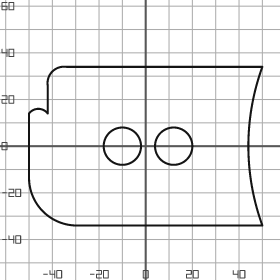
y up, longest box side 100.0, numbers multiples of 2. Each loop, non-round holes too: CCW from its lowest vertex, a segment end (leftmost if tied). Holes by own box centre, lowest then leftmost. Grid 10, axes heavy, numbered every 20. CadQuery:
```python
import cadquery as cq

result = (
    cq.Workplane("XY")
    .moveTo(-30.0, -34.0)
    .lineTo(50.0, -34.0)
    .threePointArc((44.0, 0.0), (50.0, 34.0))
    .lineTo(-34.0, 34.0)
    .threePointArc((-40.0, 32.0), (-42.0, 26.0))
    .lineTo(-42.0, 14.0)
    .threePointArc((-46.0, 16.0), (-50.0, 14.0))
    .lineTo(-50.0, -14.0)
    .threePointArc((-44.0, -28.0), (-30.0, -34.0))
    .close()
    .moveTo(-10.0, 0.0)
    .circle(8.0)
    .moveTo(12.0, 0.0)
    .circle(8.0)
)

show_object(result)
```